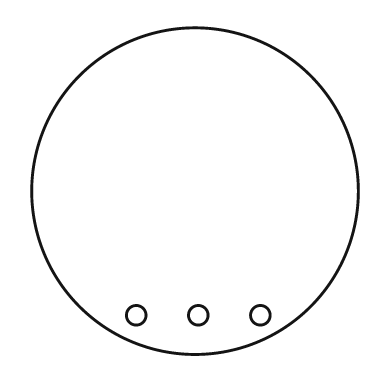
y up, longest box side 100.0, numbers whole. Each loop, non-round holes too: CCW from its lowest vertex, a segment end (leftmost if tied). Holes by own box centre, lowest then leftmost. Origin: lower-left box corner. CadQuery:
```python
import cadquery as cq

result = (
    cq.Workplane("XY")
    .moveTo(50.0, 50.0)
    .circle(50.0)
    .moveTo(32.0, 12.0)
    .circle(3.0)
    .moveTo(51.0, 12.0)
    .circle(3.0)
    .moveTo(70.0, 12.0)
    .circle(3.0)
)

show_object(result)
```